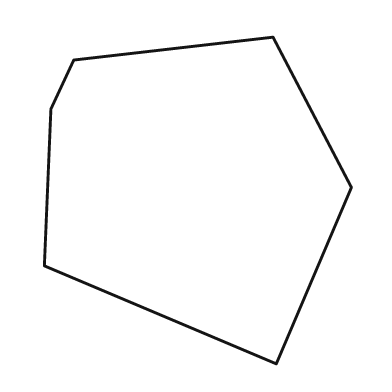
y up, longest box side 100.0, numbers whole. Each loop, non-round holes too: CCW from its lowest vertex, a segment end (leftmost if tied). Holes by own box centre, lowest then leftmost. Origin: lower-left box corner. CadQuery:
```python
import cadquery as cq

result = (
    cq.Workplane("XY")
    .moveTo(71.0, 0.0)
    .lineTo(94.0, 54.0)
    .lineTo(70.0, 100.0)
    .lineTo(9.0, 93.0)
    .lineTo(2.0, 78.0)
    .lineTo(0.0, 30.0)
    .close()
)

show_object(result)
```